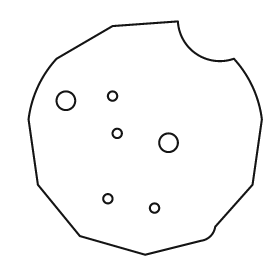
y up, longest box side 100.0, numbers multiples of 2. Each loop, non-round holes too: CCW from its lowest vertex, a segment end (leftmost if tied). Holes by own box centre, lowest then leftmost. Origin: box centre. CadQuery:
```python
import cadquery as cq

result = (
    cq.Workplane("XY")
    .moveTo(0.0, -50.0)
    .lineTo(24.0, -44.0)
    .threePointArc((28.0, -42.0), (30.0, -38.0))
    .lineTo(46.0, -20.0)
    .lineTo(50.0, 8.0)
    .threePointArc((46.0, 22.0), (38.0, 34.0))
    .threePointArc((22.0, 36.0), (14.0, 50.0))
    .lineTo(-14.0, 48.0)
    .lineTo(-38.0, 34.0)
    .threePointArc((-46.0, 22.0), (-50.0, 8.0))
    .lineTo(-46.0, -20.0)
    .lineTo(-28.0, -42.0)
    .close()
    .moveTo(4.0, -30.0)
    .circle(2.0)
    .moveTo(-16.0, -26.0)
    .circle(2.0)
    .moveTo(10.0, -2.0)
    .circle(4.0)
    .moveTo(-12.0, 2.0)
    .circle(2.0)
    .moveTo(-34.0, 16.0)
    .circle(4.0)
    .moveTo(-14.0, 18.0)
    .circle(2.0)
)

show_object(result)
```